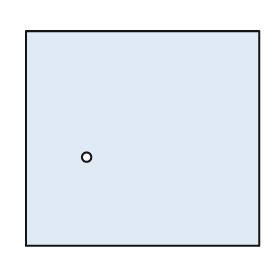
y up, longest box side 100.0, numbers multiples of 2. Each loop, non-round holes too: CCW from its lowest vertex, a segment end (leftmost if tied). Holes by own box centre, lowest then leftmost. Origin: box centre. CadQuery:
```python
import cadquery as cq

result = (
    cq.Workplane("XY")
    .moveTo(-50.0, -46.0)
    .lineTo(50.0, -46.0)
    .lineTo(50.0, 46.0)
    .lineTo(-50.0, 46.0)
    .close()
    .moveTo(-24.0, -8.0)
    .circle(2.0)
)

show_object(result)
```